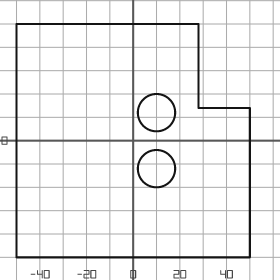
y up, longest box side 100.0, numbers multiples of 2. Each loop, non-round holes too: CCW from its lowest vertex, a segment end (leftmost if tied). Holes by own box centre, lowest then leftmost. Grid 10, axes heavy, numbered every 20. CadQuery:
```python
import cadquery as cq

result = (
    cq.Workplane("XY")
    .moveTo(-50.0, -50.0)
    .lineTo(50.0, -50.0)
    .lineTo(50.0, 14.0)
    .lineTo(28.0, 14.0)
    .lineTo(28.0, 50.0)
    .lineTo(-50.0, 50.0)
    .close()
    .moveTo(10.0, -12.0)
    .circle(8.0)
    .moveTo(10.0, 12.0)
    .circle(8.0)
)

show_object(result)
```